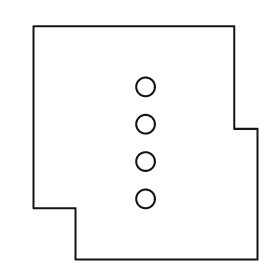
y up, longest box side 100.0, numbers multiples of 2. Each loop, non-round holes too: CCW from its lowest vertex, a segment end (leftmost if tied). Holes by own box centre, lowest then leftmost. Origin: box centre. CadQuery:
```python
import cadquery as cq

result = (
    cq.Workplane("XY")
    .moveTo(-30.0, -50.0)
    .lineTo(48.0, -50.0)
    .lineTo(48.0, 6.0)
    .lineTo(38.0, 6.0)
    .lineTo(38.0, 50.0)
    .lineTo(-48.0, 50.0)
    .lineTo(-48.0, -28.0)
    .lineTo(-30.0, -28.0)
    .close()
    .moveTo(0.0, -24.0)
    .circle(4.0)
    .moveTo(0.0, -8.0)
    .circle(4.0)
    .moveTo(0.0, 8.0)
    .circle(4.0)
    .moveTo(0.0, 24.0)
    .circle(4.0)
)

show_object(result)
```